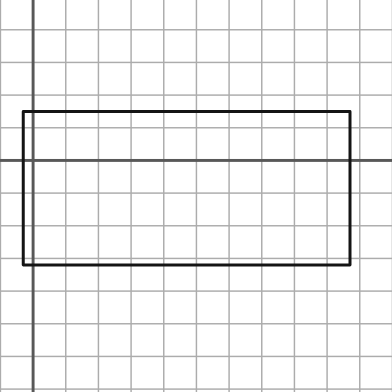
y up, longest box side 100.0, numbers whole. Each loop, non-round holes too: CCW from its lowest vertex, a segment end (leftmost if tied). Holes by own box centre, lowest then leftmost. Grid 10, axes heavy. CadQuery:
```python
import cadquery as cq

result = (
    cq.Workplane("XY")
    .moveTo(-3.0, -32.0)
    .lineTo(97.0, -32.0)
    .lineTo(97.0, 15.0)
    .lineTo(-3.0, 15.0)
    .close()
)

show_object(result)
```